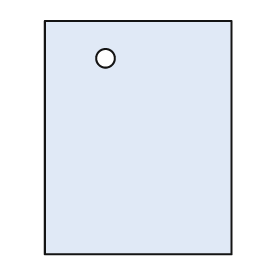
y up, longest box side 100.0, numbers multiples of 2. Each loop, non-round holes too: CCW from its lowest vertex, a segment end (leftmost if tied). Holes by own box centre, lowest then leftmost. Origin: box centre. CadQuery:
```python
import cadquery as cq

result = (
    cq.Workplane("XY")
    .moveTo(-40.0, -50.0)
    .lineTo(40.0, -50.0)
    .lineTo(40.0, 50.0)
    .lineTo(-40.0, 50.0)
    .close()
    .moveTo(-14.0, 34.0)
    .circle(4.0)
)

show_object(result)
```